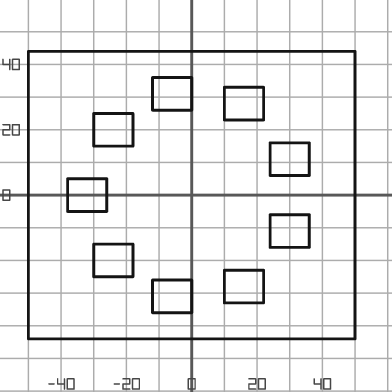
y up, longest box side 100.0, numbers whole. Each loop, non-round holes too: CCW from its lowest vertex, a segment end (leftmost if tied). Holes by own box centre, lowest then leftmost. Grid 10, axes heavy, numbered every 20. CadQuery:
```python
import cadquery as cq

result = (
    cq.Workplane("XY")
    .moveTo(-50.0, -44.0)
    .lineTo(50.0, -44.0)
    .lineTo(50.0, 44.0)
    .lineTo(-50.0, 44.0)
    .close()
    .moveTo(-12.0, -36.0)
    .lineTo(0.0, -36.0)
    .lineTo(0.0, -26.0)
    .lineTo(-12.0, -26.0)
    .close()
    .moveTo(10.0, -33.0)
    .lineTo(22.0, -33.0)
    .lineTo(22.0, -23.0)
    .lineTo(10.0, -23.0)
    .close()
    .moveTo(-30.0, -25.0)
    .lineTo(-18.0, -25.0)
    .lineTo(-18.0, -15.0)
    .lineTo(-30.0, -15.0)
    .close()
    .moveTo(24.0, -16.0)
    .lineTo(36.0, -16.0)
    .lineTo(36.0, -6.0)
    .lineTo(24.0, -6.0)
    .close()
    .moveTo(-38.0, -5.0)
    .lineTo(-26.0, -5.0)
    .lineTo(-26.0, 5.0)
    .lineTo(-38.0, 5.0)
    .close()
    .moveTo(24.0, 6.0)
    .lineTo(36.0, 6.0)
    .lineTo(36.0, 16.0)
    .lineTo(24.0, 16.0)
    .close()
    .moveTo(-30.0, 15.0)
    .lineTo(-18.0, 15.0)
    .lineTo(-18.0, 25.0)
    .lineTo(-30.0, 25.0)
    .close()
    .moveTo(10.0, 23.0)
    .lineTo(22.0, 23.0)
    .lineTo(22.0, 33.0)
    .lineTo(10.0, 33.0)
    .close()
    .moveTo(-12.0, 26.0)
    .lineTo(0.0, 26.0)
    .lineTo(0.0, 36.0)
    .lineTo(-12.0, 36.0)
    .close()
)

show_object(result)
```